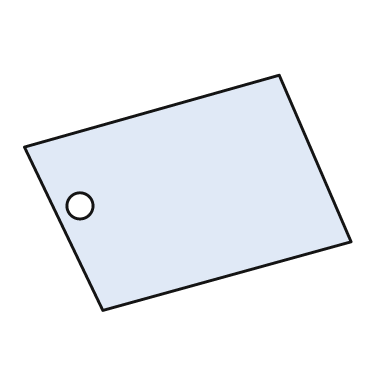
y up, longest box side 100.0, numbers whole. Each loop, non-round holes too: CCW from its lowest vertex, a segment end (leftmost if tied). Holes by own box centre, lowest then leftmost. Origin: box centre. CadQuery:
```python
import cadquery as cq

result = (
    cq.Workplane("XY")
    .moveTo(-26.0, -36.0)
    .lineTo(50.0, -15.0)
    .lineTo(28.0, 36.0)
    .lineTo(-50.0, 14.0)
    .close()
    .moveTo(-33.0, -4.0)
    .circle(4.0)
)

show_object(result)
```